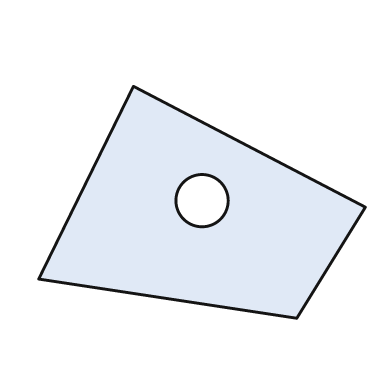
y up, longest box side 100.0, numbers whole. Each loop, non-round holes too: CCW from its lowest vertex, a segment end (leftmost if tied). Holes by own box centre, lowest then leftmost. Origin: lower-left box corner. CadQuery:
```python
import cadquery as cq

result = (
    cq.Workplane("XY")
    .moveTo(79.0, 0.0)
    .lineTo(100.0, 34.0)
    .lineTo(29.0, 71.0)
    .lineTo(0.0, 12.0)
    .close()
    .moveTo(50.0, 36.0)
    .circle(8.0)
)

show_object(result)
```